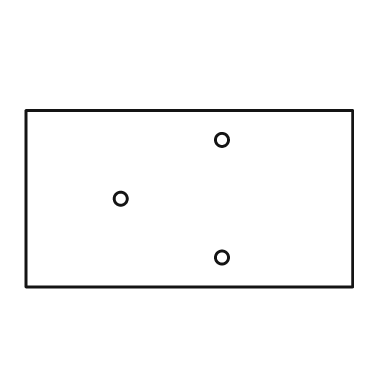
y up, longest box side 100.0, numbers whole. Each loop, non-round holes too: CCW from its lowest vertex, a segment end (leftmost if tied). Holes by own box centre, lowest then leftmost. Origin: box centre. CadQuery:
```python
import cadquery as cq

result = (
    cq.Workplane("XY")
    .moveTo(-50.0, -27.0)
    .lineTo(50.0, -27.0)
    .lineTo(50.0, 27.0)
    .lineTo(-50.0, 27.0)
    .close()
    .moveTo(10.0, -18.0)
    .circle(2.0)
    .moveTo(-21.0, 0.0)
    .circle(2.0)
    .moveTo(10.0, 18.0)
    .circle(2.0)
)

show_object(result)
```